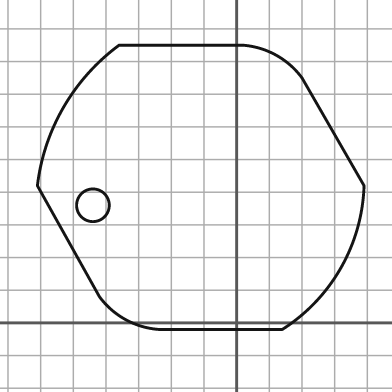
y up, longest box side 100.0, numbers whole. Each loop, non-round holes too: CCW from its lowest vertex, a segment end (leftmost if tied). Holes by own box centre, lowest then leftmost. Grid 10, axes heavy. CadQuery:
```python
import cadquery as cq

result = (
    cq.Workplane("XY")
    .moveTo(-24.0, -2.0)
    .lineTo(14.0, -2.0)
    .threePointArc((32.0, 17.0), (39.0, 42.0))
    .lineTo(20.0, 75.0)
    .threePointArc((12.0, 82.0), (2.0, 85.0))
    .lineTo(-36.0, 85.0)
    .threePointArc((-53.0, 66.0), (-61.0, 42.0))
    .lineTo(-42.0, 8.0)
    .threePointArc((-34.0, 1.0), (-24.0, -2.0))
    .close()
    .moveTo(-44.0, 36.0)
    .circle(5.0)
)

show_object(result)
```